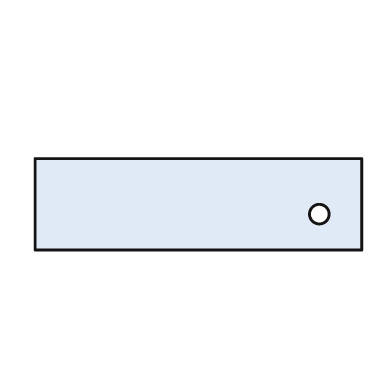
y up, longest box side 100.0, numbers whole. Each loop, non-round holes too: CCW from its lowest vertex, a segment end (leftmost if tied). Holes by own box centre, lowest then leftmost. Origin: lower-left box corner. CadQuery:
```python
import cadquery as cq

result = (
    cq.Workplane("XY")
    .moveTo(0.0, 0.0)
    .lineTo(100.0, 0.0)
    .lineTo(100.0, 28.0)
    .lineTo(0.0, 28.0)
    .close()
    .moveTo(87.0, 11.0)
    .circle(3.0)
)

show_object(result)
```